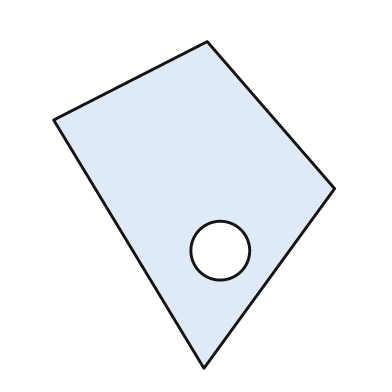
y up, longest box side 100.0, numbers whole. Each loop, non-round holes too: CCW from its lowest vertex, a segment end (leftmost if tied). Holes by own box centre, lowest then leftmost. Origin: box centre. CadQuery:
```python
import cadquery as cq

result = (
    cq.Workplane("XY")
    .moveTo(3.0, -50.0)
    .lineTo(43.0, 5.0)
    .lineTo(4.0, 50.0)
    .lineTo(-43.0, 26.0)
    .close()
    .moveTo(8.0, -14.0)
    .circle(9.0)
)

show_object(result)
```